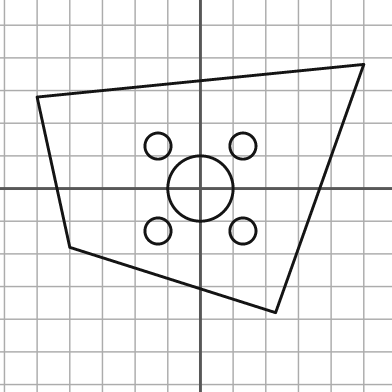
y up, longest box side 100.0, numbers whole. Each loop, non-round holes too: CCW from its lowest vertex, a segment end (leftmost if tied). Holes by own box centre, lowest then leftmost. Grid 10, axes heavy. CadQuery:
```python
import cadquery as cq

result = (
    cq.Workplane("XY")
    .moveTo(23.0, -38.0)
    .lineTo(50.0, 38.0)
    .lineTo(-50.0, 28.0)
    .lineTo(-40.0, -18.0)
    .close()
    .moveTo(-13.0, -13.0)
    .circle(4.0)
    .moveTo(13.0, -13.0)
    .circle(4.0)
    .moveTo(0.0, 0.0)
    .circle(10.0)
    .moveTo(-13.0, 13.0)
    .circle(4.0)
    .moveTo(13.0, 13.0)
    .circle(4.0)
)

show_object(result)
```